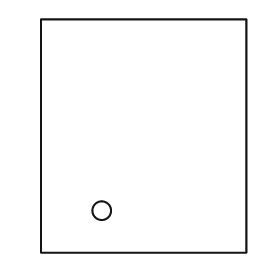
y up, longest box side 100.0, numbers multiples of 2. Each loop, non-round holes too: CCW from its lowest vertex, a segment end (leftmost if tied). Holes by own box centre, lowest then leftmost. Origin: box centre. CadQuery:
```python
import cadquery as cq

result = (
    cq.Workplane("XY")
    .moveTo(-44.0, -50.0)
    .lineTo(44.0, -50.0)
    .lineTo(44.0, 50.0)
    .lineTo(-44.0, 50.0)
    .close()
    .moveTo(-18.0, -32.0)
    .circle(4.0)
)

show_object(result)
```